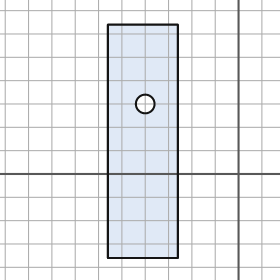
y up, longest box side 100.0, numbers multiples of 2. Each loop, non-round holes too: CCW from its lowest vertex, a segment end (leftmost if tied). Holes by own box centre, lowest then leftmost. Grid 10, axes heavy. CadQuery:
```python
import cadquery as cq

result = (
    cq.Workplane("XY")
    .moveTo(-56.0, -36.0)
    .lineTo(-26.0, -36.0)
    .lineTo(-26.0, 64.0)
    .lineTo(-56.0, 64.0)
    .close()
    .moveTo(-40.0, 30.0)
    .circle(4.0)
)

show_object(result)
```